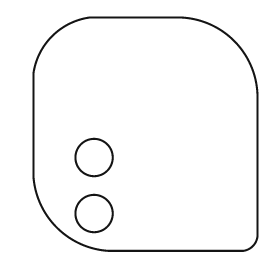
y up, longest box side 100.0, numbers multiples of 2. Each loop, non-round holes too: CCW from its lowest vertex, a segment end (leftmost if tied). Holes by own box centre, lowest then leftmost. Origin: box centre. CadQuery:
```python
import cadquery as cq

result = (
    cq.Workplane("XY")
    .moveTo(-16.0, -50.0)
    .lineTo(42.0, -50.0)
    .threePointArc((46.0, -48.0), (48.0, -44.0))
    .lineTo(48.0, 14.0)
    .threePointArc((38.0, 40.0), (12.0, 50.0))
    .lineTo(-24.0, 50.0)
    .threePointArc((-40.0, 42.0), (-48.0, 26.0))
    .lineTo(-48.0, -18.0)
    .threePointArc((-38.0, -40.0), (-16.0, -50.0))
    .close()
    .moveTo(-22.0, -34.0)
    .circle(8.0)
    .moveTo(-22.0, -10.0)
    .circle(8.0)
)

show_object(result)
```